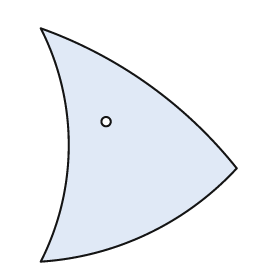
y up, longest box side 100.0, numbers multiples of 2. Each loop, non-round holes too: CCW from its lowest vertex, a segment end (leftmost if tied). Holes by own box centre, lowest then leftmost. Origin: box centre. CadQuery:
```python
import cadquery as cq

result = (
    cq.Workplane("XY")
    .moveTo(-42.0, -50.0)
    .threePointArc((4.0, -38.0), (42.0, -10.0))
    .threePointArc((4.0, 26.0), (-42.0, 50.0))
    .threePointArc((-30.0, 0.0), (-42.0, -50.0))
    .close()
    .moveTo(-14.0, 10.0)
    .circle(2.0)
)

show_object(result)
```